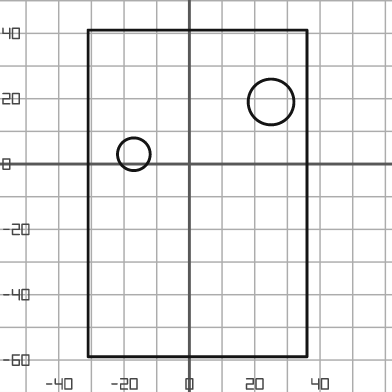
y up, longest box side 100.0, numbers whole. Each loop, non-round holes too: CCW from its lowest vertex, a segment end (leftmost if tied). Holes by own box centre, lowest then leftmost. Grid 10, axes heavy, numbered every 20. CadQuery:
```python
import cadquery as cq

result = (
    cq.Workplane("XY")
    .moveTo(-31.0, -59.0)
    .lineTo(36.0, -59.0)
    .lineTo(36.0, 41.0)
    .lineTo(-31.0, 41.0)
    .close()
    .moveTo(-17.0, 3.0)
    .circle(5.0)
    .moveTo(25.0, 19.0)
    .circle(7.0)
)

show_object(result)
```